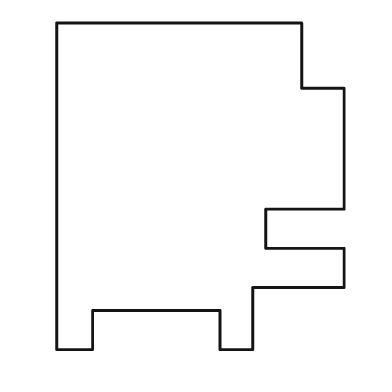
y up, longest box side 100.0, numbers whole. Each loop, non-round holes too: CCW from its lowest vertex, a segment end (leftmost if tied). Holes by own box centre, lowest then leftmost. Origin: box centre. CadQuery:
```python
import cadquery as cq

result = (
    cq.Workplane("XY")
    .moveTo(-44.0, -50.0)
    .lineTo(-33.0, -50.0)
    .lineTo(-33.0, -38.0)
    .lineTo(6.0, -38.0)
    .lineTo(6.0, -50.0)
    .lineTo(16.0, -50.0)
    .lineTo(16.0, -31.0)
    .lineTo(44.0, -31.0)
    .lineTo(44.0, -19.0)
    .lineTo(20.0, -19.0)
    .lineTo(20.0, -7.0)
    .lineTo(44.0, -7.0)
    .lineTo(44.0, 30.0)
    .lineTo(31.0, 30.0)
    .lineTo(31.0, 50.0)
    .lineTo(-44.0, 50.0)
    .close()
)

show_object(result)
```